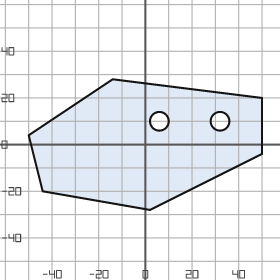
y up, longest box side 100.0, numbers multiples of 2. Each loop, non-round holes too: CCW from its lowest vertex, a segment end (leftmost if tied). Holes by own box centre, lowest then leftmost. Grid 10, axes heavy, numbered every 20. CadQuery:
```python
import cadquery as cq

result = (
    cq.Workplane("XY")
    .moveTo(2.0, -28.0)
    .lineTo(50.0, -4.0)
    .lineTo(50.0, 20.0)
    .lineTo(-14.0, 28.0)
    .lineTo(-50.0, 4.0)
    .lineTo(-44.0, -20.0)
    .close()
    .moveTo(6.0, 10.0)
    .circle(4.0)
    .moveTo(32.0, 10.0)
    .circle(4.0)
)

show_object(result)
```